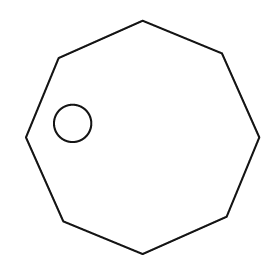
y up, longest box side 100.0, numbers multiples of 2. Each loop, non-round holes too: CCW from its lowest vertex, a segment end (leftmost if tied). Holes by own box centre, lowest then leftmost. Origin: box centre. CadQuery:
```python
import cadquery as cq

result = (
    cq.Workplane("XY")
    .moveTo(0.0, -50.0)
    .lineTo(36.0, -34.0)
    .lineTo(50.0, 0.0)
    .lineTo(34.0, 36.0)
    .lineTo(0.0, 50.0)
    .lineTo(-36.0, 34.0)
    .lineTo(-50.0, 0.0)
    .lineTo(-34.0, -36.0)
    .close()
    .moveTo(-30.0, 6.0)
    .circle(8.0)
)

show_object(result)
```